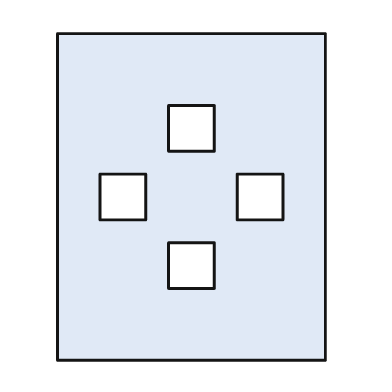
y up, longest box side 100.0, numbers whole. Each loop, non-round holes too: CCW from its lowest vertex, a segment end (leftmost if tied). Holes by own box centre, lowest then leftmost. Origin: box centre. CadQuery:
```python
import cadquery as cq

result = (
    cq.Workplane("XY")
    .moveTo(-41.0, -50.0)
    .lineTo(41.0, -50.0)
    .lineTo(41.0, 50.0)
    .lineTo(-41.0, 50.0)
    .close()
    .moveTo(-7.0, -28.0)
    .lineTo(7.0, -28.0)
    .lineTo(7.0, -14.0)
    .lineTo(-7.0, -14.0)
    .close()
    .moveTo(-28.0, -7.0)
    .lineTo(-14.0, -7.0)
    .lineTo(-14.0, 7.0)
    .lineTo(-28.0, 7.0)
    .close()
    .moveTo(14.0, -7.0)
    .lineTo(28.0, -7.0)
    .lineTo(28.0, 7.0)
    .lineTo(14.0, 7.0)
    .close()
    .moveTo(-7.0, 14.0)
    .lineTo(7.0, 14.0)
    .lineTo(7.0, 28.0)
    .lineTo(-7.0, 28.0)
    .close()
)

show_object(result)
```